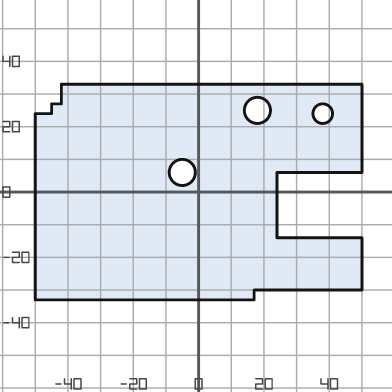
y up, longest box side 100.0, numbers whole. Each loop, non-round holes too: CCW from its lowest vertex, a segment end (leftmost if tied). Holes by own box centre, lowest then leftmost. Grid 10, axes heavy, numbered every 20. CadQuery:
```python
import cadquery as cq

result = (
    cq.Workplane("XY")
    .moveTo(-50.0, -33.0)
    .lineTo(17.0, -33.0)
    .lineTo(17.0, -30.0)
    .lineTo(50.0, -30.0)
    .lineTo(50.0, -14.0)
    .lineTo(24.0, -14.0)
    .lineTo(24.0, 6.0)
    .lineTo(50.0, 6.0)
    .lineTo(50.0, 33.0)
    .lineTo(-42.0, 33.0)
    .lineTo(-42.0, 27.0)
    .lineTo(-45.0, 27.0)
    .lineTo(-45.0, 24.0)
    .lineTo(-50.0, 24.0)
    .close()
    .moveTo(-5.0, 6.0)
    .circle(4.0)
    .moveTo(38.0, 24.0)
    .circle(3.0)
    .moveTo(18.0, 25.0)
    .circle(4.0)
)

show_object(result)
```